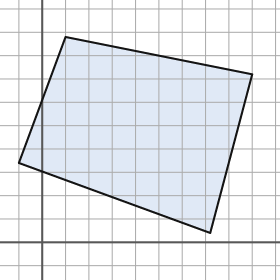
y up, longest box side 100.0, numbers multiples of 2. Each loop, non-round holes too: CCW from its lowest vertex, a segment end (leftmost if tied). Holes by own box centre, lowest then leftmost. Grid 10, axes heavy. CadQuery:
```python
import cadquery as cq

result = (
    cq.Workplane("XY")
    .moveTo(72.0, 4.0)
    .lineTo(90.0, 72.0)
    .lineTo(10.0, 88.0)
    .lineTo(-10.0, 34.0)
    .close()
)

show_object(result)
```